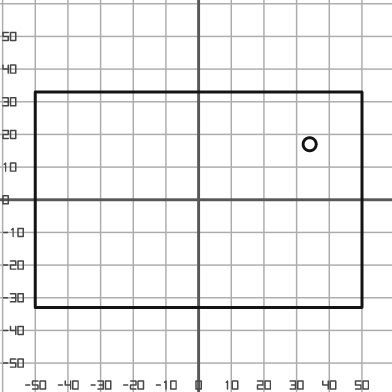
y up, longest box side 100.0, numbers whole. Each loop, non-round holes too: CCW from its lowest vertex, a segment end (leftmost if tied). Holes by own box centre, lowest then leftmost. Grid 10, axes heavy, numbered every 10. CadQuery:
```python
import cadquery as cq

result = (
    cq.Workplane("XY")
    .moveTo(-50.0, -33.0)
    .lineTo(50.0, -33.0)
    .lineTo(50.0, 33.0)
    .lineTo(-50.0, 33.0)
    .close()
    .moveTo(34.0, 17.0)
    .circle(2.0)
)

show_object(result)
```